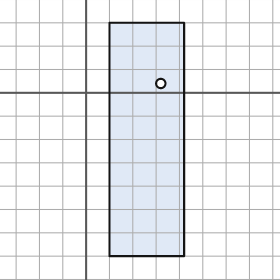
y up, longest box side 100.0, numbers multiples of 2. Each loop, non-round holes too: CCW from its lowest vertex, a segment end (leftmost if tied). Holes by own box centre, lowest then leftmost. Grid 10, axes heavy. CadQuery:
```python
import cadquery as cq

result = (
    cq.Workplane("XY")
    .moveTo(10.0, -70.0)
    .lineTo(42.0, -70.0)
    .lineTo(42.0, 30.0)
    .lineTo(10.0, 30.0)
    .close()
    .moveTo(32.0, 4.0)
    .circle(2.0)
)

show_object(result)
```